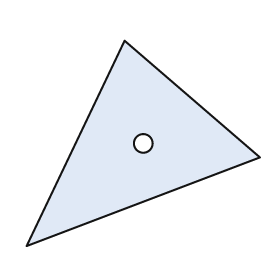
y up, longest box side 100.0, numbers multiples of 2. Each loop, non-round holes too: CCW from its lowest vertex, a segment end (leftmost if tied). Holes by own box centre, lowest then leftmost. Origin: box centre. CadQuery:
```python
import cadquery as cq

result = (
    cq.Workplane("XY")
    .moveTo(-50.0, -44.0)
    .lineTo(50.0, -6.0)
    .lineTo(-8.0, 44.0)
    .close()
    .moveTo(0.0, 0.0)
    .circle(4.0)
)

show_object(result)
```